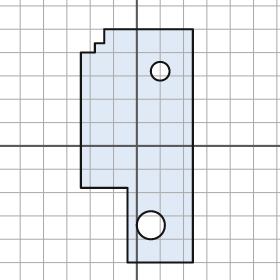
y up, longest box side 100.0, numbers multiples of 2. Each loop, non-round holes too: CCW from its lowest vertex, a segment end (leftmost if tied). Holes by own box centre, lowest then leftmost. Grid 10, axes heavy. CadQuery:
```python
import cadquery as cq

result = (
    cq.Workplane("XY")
    .moveTo(-4.0, -50.0)
    .lineTo(24.0, -50.0)
    .lineTo(24.0, 50.0)
    .lineTo(-14.0, 50.0)
    .lineTo(-14.0, 44.0)
    .lineTo(-18.0, 44.0)
    .lineTo(-18.0, 40.0)
    .lineTo(-24.0, 40.0)
    .lineTo(-24.0, -18.0)
    .lineTo(-4.0, -18.0)
    .close()
    .moveTo(6.0, -34.0)
    .circle(6.0)
    .moveTo(10.0, 32.0)
    .circle(4.0)
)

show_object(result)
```